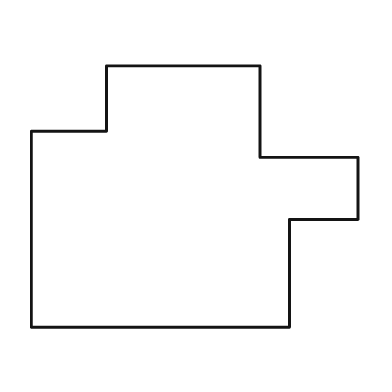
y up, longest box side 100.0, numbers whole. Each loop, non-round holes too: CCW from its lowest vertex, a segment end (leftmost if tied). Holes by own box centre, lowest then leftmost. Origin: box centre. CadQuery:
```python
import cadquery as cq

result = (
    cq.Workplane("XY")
    .moveTo(-50.0, -40.0)
    .lineTo(29.0, -40.0)
    .lineTo(29.0, -7.0)
    .lineTo(50.0, -7.0)
    .lineTo(50.0, 12.0)
    .lineTo(20.0, 12.0)
    .lineTo(20.0, 40.0)
    .lineTo(-27.0, 40.0)
    .lineTo(-27.0, 20.0)
    .lineTo(-50.0, 20.0)
    .close()
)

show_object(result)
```